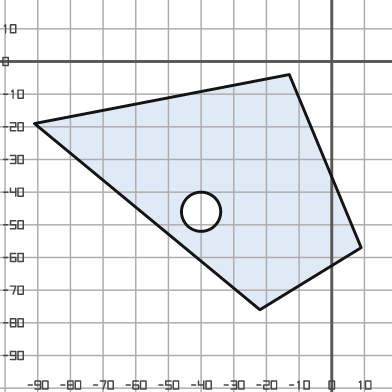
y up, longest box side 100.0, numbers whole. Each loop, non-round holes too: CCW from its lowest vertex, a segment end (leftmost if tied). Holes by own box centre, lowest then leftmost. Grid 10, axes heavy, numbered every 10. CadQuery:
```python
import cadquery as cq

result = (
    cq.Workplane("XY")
    .moveTo(-22.0, -76.0)
    .lineTo(9.0, -57.0)
    .lineTo(-13.0, -4.0)
    .lineTo(-91.0, -19.0)
    .close()
    .moveTo(-40.0, -46.0)
    .circle(6.0)
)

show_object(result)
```